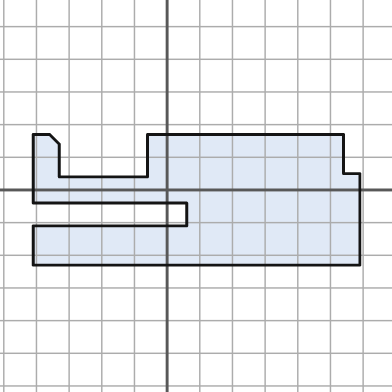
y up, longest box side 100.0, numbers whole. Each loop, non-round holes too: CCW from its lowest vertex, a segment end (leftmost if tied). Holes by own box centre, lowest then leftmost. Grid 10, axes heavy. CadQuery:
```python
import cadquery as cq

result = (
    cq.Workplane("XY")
    .moveTo(-41.0, -23.0)
    .lineTo(59.0, -23.0)
    .lineTo(59.0, 5.0)
    .lineTo(54.0, 5.0)
    .lineTo(54.0, 17.0)
    .lineTo(-6.0, 17.0)
    .lineTo(-6.0, 4.0)
    .lineTo(-33.0, 4.0)
    .lineTo(-33.0, 14.0)
    .lineTo(-36.0, 17.0)
    .lineTo(-41.0, 17.0)
    .lineTo(-41.0, -4.0)
    .lineTo(6.0, -4.0)
    .lineTo(6.0, -11.0)
    .lineTo(-41.0, -11.0)
    .close()
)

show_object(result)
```